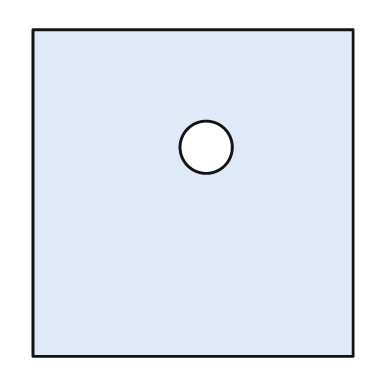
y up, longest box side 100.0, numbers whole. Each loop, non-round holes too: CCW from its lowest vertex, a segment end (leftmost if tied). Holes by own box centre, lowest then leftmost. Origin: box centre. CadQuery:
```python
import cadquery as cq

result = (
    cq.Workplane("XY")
    .moveTo(-49.0, -50.0)
    .lineTo(49.0, -50.0)
    .lineTo(49.0, 50.0)
    .lineTo(-49.0, 50.0)
    .close()
    .moveTo(4.0, 14.0)
    .circle(8.0)
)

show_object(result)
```